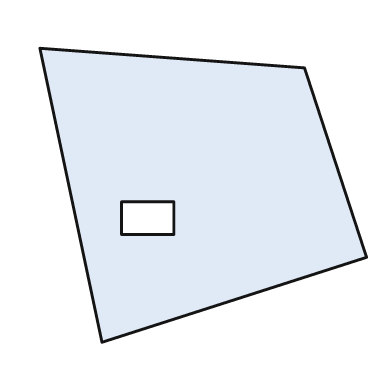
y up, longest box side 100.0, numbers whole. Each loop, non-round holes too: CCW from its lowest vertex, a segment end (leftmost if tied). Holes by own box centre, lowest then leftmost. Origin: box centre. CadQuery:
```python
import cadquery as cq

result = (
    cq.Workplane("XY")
    .moveTo(-31.0, -45.0)
    .lineTo(50.0, -19.0)
    .lineTo(31.0, 39.0)
    .lineTo(-50.0, 45.0)
    .close()
    .moveTo(-25.0, -12.0)
    .lineTo(-9.0, -12.0)
    .lineTo(-9.0, -2.0)
    .lineTo(-25.0, -2.0)
    .close()
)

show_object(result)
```